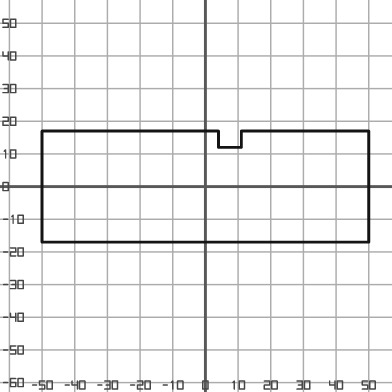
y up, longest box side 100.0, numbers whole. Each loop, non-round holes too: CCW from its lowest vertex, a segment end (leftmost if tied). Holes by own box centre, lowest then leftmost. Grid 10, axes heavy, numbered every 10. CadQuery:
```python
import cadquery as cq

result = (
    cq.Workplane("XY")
    .moveTo(-50.0, -17.0)
    .lineTo(50.0, -17.0)
    .lineTo(50.0, 17.0)
    .lineTo(11.0, 17.0)
    .lineTo(11.0, 12.0)
    .lineTo(4.0, 12.0)
    .lineTo(4.0, 17.0)
    .lineTo(-50.0, 17.0)
    .close()
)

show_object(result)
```